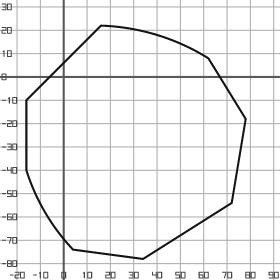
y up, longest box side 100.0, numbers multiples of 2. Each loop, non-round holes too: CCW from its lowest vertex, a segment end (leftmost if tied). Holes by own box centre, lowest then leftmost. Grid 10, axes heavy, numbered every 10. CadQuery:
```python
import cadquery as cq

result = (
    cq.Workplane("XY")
    .moveTo(34.0, -78.0)
    .lineTo(72.0, -54.0)
    .lineTo(78.0, -18.0)
    .lineTo(62.0, 8.0)
    .threePointArc((40.0, 18.0), (16.0, 22.0))
    .lineTo(-16.0, -10.0)
    .lineTo(-16.0, -40.0)
    .threePointArc((-8.0, -58.0), (4.0, -74.0))
    .close()
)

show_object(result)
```